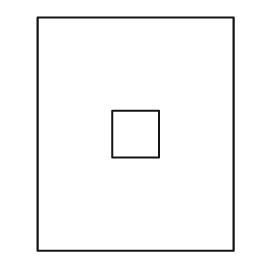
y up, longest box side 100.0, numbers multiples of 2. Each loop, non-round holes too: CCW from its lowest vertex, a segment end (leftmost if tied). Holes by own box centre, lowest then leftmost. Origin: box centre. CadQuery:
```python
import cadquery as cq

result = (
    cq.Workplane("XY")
    .moveTo(-42.0, -50.0)
    .lineTo(42.0, -50.0)
    .lineTo(42.0, 50.0)
    .lineTo(-42.0, 50.0)
    .close()
    .moveTo(-10.0, -10.0)
    .lineTo(10.0, -10.0)
    .lineTo(10.0, 10.0)
    .lineTo(-10.0, 10.0)
    .close()
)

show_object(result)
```